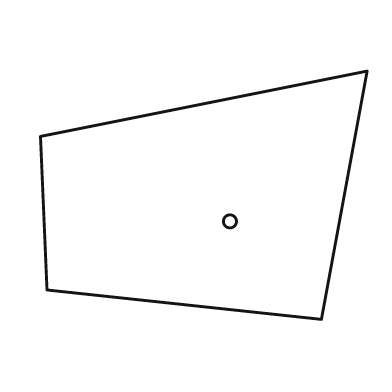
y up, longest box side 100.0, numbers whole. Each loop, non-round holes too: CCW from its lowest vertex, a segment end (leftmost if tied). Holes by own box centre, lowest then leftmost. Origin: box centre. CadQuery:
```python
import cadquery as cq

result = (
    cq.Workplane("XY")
    .moveTo(36.0, -38.0)
    .lineTo(50.0, 38.0)
    .lineTo(-50.0, 18.0)
    .lineTo(-48.0, -29.0)
    .close()
    .moveTo(8.0, -8.0)
    .circle(2.0)
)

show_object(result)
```